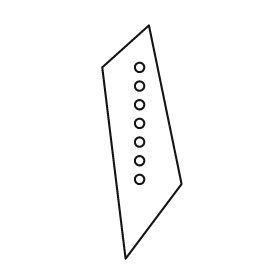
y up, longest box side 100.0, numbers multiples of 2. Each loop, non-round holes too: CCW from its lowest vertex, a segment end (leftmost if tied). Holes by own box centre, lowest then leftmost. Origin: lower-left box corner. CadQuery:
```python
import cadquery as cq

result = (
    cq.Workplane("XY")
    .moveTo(10.0, 0.0)
    .lineTo(34.0, 32.0)
    .lineTo(20.0, 100.0)
    .lineTo(0.0, 82.0)
    .close()
    .moveTo(16.0, 34.0)
    .circle(2.0)
    .moveTo(16.0, 42.0)
    .circle(2.0)
    .moveTo(16.0, 50.0)
    .circle(2.0)
    .moveTo(16.0, 58.0)
    .circle(2.0)
    .moveTo(16.0, 66.0)
    .circle(2.0)
    .moveTo(16.0, 74.0)
    .circle(2.0)
    .moveTo(16.0, 82.0)
    .circle(2.0)
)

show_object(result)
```